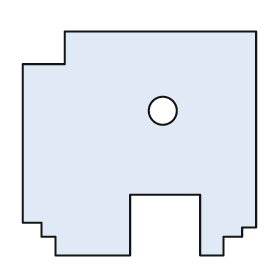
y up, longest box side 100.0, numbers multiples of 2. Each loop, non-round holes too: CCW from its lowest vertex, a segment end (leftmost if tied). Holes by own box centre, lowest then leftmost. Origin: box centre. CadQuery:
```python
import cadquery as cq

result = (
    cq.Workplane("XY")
    .moveTo(-36.0, -48.0)
    .lineTo(-4.0, -48.0)
    .lineTo(-4.0, -22.0)
    .lineTo(26.0, -22.0)
    .lineTo(26.0, -48.0)
    .lineTo(36.0, -48.0)
    .lineTo(36.0, -40.0)
    .lineTo(44.0, -40.0)
    .lineTo(44.0, -36.0)
    .lineTo(50.0, -36.0)
    .lineTo(50.0, 48.0)
    .lineTo(-32.0, 48.0)
    .lineTo(-32.0, 34.0)
    .lineTo(-50.0, 34.0)
    .lineTo(-50.0, -34.0)
    .lineTo(-42.0, -34.0)
    .lineTo(-42.0, -40.0)
    .lineTo(-36.0, -40.0)
    .close()
    .moveTo(10.0, 14.0)
    .circle(6.0)
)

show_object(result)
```